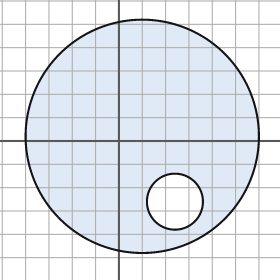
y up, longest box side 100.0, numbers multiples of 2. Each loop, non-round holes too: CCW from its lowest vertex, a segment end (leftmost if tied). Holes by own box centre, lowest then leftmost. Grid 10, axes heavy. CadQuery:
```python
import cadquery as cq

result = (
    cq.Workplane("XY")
    .moveTo(10.0, 2.0)
    .circle(50.0)
    .moveTo(24.0, -26.0)
    .circle(12.0)
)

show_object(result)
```